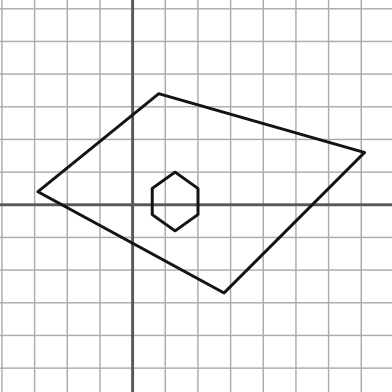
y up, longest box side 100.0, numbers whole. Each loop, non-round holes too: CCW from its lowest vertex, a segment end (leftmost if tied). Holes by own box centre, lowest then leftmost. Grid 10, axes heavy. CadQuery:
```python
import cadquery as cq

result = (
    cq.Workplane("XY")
    .moveTo(28.0, -27.0)
    .lineTo(71.0, 16.0)
    .lineTo(8.0, 34.0)
    .lineTo(-29.0, 4.0)
    .close()
    .moveTo(13.0, -8.0)
    .lineTo(20.0, -3.0)
    .lineTo(20.0, 5.0)
    .lineTo(13.0, 10.0)
    .lineTo(6.0, 5.0)
    .lineTo(6.0, -3.0)
    .close()
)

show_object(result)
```